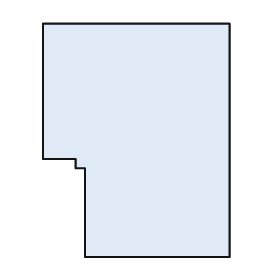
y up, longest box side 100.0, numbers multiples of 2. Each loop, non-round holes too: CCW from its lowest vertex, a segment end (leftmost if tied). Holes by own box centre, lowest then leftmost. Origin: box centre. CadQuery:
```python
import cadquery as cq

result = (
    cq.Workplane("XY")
    .moveTo(-22.0, -50.0)
    .lineTo(40.0, -50.0)
    .lineTo(40.0, 50.0)
    .lineTo(-40.0, 50.0)
    .lineTo(-40.0, -8.0)
    .lineTo(-26.0, -8.0)
    .lineTo(-26.0, -12.0)
    .lineTo(-22.0, -12.0)
    .close()
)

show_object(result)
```